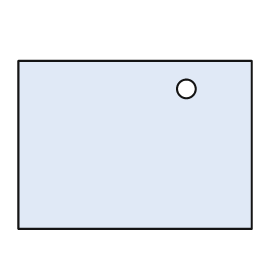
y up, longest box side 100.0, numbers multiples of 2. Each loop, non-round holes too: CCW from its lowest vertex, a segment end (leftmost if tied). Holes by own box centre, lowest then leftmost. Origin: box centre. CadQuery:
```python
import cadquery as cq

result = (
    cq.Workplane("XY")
    .moveTo(-50.0, -36.0)
    .lineTo(50.0, -36.0)
    .lineTo(50.0, 36.0)
    .lineTo(-50.0, 36.0)
    .close()
    .moveTo(22.0, 24.0)
    .circle(4.0)
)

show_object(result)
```